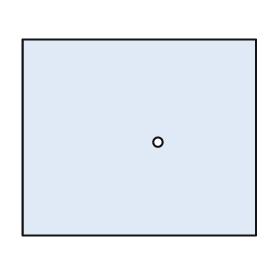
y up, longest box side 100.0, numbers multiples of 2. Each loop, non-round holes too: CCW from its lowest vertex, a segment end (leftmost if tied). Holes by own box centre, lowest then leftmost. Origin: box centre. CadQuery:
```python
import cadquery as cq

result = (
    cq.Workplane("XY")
    .moveTo(-50.0, -42.0)
    .lineTo(50.0, -42.0)
    .lineTo(50.0, 42.0)
    .lineTo(-50.0, 42.0)
    .close()
    .moveTo(8.0, -2.0)
    .circle(2.0)
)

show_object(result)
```